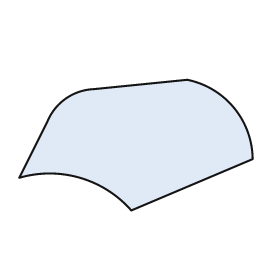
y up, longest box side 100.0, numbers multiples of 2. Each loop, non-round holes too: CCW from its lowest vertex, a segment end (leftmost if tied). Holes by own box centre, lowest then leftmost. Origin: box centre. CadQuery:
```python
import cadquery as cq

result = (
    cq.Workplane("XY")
    .moveTo(-2.0, -28.0)
    .lineTo(50.0, -6.0)
    .threePointArc((42.0, 16.0), (22.0, 28.0))
    .lineTo(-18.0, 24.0)
    .threePointArc((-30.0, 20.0), (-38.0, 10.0))
    .lineTo(-50.0, -14.0)
    .threePointArc((-24.0, -14.0), (-2.0, -28.0))
    .close()
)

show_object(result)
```